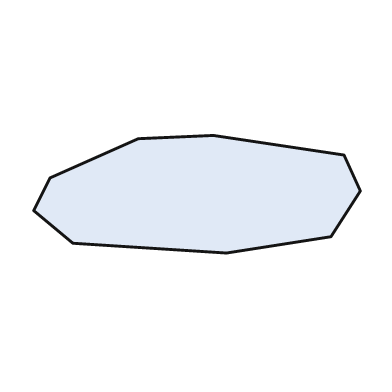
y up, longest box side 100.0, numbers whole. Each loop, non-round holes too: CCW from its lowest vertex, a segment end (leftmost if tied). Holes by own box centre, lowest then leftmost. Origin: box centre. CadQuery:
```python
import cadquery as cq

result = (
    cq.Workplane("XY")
    .moveTo(9.0, -18.0)
    .lineTo(41.0, -13.0)
    .lineTo(50.0, 1.0)
    .lineTo(45.0, 12.0)
    .lineTo(5.0, 18.0)
    .lineTo(-18.0, 17.0)
    .lineTo(-45.0, 5.0)
    .lineTo(-50.0, -5.0)
    .lineTo(-38.0, -15.0)
    .close()
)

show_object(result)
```